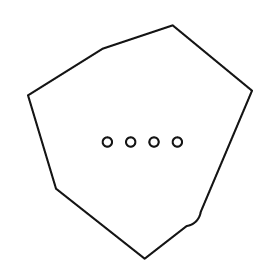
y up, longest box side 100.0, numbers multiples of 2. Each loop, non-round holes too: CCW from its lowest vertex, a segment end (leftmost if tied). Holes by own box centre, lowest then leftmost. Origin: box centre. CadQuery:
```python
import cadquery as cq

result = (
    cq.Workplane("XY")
    .moveTo(2.0, -50.0)
    .lineTo(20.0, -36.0)
    .threePointArc((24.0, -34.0), (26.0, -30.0))
    .lineTo(48.0, 22.0)
    .lineTo(14.0, 50.0)
    .lineTo(-16.0, 40.0)
    .lineTo(-48.0, 20.0)
    .lineTo(-36.0, -20.0)
    .close()
    .moveTo(-14.0, 0.0)
    .circle(2.0)
    .moveTo(-4.0, 0.0)
    .circle(2.0)
    .moveTo(6.0, 0.0)
    .circle(2.0)
    .moveTo(16.0, 0.0)
    .circle(2.0)
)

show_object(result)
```